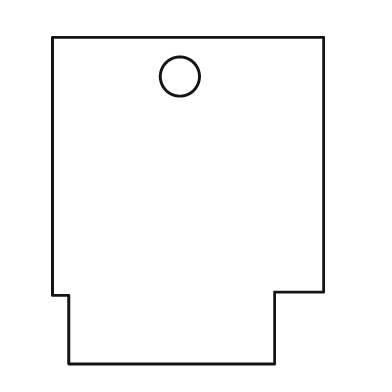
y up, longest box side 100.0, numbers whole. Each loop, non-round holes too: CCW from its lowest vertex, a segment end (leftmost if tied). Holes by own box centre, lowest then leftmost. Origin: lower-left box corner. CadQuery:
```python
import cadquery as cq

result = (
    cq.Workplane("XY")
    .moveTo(5.0, 0.0)
    .lineTo(68.0, 0.0)
    .lineTo(68.0, 22.0)
    .lineTo(83.0, 22.0)
    .lineTo(83.0, 100.0)
    .lineTo(0.0, 100.0)
    .lineTo(0.0, 21.0)
    .lineTo(5.0, 21.0)
    .close()
    .moveTo(39.0, 88.0)
    .circle(6.0)
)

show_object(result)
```